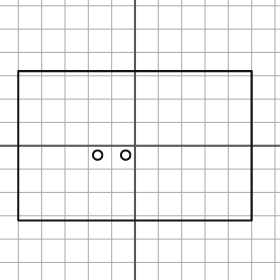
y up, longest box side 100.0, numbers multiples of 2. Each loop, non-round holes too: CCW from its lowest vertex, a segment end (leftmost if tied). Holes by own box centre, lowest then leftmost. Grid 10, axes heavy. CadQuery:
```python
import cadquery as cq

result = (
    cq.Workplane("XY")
    .moveTo(-50.0, -32.0)
    .lineTo(50.0, -32.0)
    .lineTo(50.0, 32.0)
    .lineTo(-50.0, 32.0)
    .close()
    .moveTo(-16.0, -4.0)
    .circle(2.0)
    .moveTo(-4.0, -4.0)
    .circle(2.0)
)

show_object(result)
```